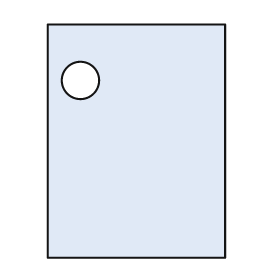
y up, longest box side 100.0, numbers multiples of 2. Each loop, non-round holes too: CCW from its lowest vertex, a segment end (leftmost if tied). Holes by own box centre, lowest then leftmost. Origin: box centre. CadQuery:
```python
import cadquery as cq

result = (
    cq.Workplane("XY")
    .moveTo(-38.0, -50.0)
    .lineTo(38.0, -50.0)
    .lineTo(38.0, 50.0)
    .lineTo(-38.0, 50.0)
    .close()
    .moveTo(-24.0, 26.0)
    .circle(8.0)
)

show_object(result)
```